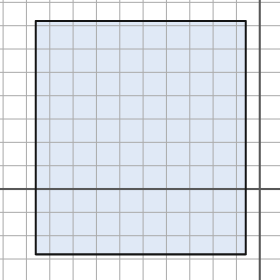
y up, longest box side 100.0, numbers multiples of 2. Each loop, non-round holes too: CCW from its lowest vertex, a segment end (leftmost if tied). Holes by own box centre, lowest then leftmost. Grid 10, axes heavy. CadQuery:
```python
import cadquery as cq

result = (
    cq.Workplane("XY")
    .moveTo(-96.0, -28.0)
    .lineTo(-6.0, -28.0)
    .lineTo(-6.0, 72.0)
    .lineTo(-96.0, 72.0)
    .close()
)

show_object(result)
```